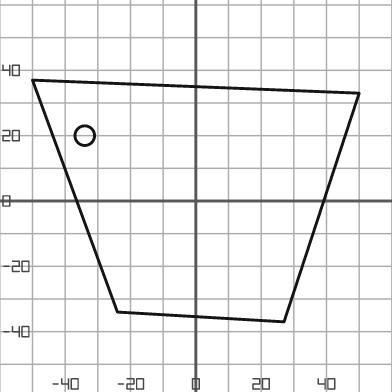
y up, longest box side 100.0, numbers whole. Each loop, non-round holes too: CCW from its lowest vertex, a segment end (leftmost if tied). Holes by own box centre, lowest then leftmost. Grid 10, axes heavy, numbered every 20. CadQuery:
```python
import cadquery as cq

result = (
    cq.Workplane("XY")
    .moveTo(27.0, -37.0)
    .lineTo(50.0, 33.0)
    .lineTo(-50.0, 37.0)
    .lineTo(-24.0, -34.0)
    .close()
    .moveTo(-34.0, 20.0)
    .circle(3.0)
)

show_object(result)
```